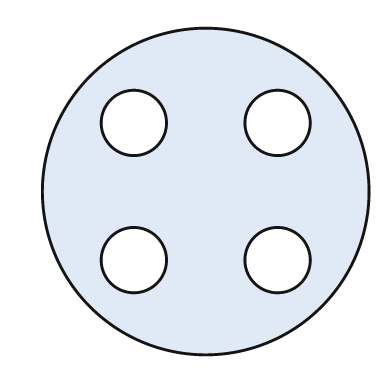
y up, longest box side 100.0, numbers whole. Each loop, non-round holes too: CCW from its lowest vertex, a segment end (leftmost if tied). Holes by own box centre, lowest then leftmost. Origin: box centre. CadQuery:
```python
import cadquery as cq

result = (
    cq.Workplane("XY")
    .moveTo(0.0, 0.0)
    .circle(50.0)
    .moveTo(-22.0, -21.0)
    .circle(10.0)
    .moveTo(22.0, -21.0)
    .circle(10.0)
    .moveTo(-22.0, 21.0)
    .circle(10.0)
    .moveTo(22.0, 21.0)
    .circle(10.0)
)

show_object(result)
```